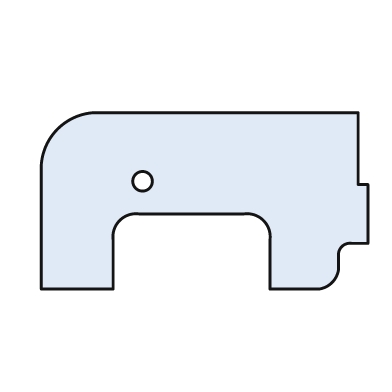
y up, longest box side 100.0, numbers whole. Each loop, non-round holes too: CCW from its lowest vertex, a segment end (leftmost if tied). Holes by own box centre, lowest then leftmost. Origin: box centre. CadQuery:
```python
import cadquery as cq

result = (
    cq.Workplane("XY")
    .moveTo(-50.0, -27.0)
    .lineTo(-28.0, -27.0)
    .lineTo(-28.0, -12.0)
    .threePointArc((-26.0, -6.0), (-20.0, -4.0))
    .lineTo(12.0, -4.0)
    .threePointArc((18.0, -6.0), (20.0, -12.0))
    .lineTo(20.0, -27.0)
    .lineTo(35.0, -27.0)
    .threePointArc((39.0, -25.0), (41.0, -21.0))
    .lineTo(41.0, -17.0)
    .threePointArc((42.0, -14.0), (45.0, -13.0))
    .lineTo(50.0, -13.0)
    .lineTo(50.0, 5.0)
    .lineTo(47.0, 5.0)
    .lineTo(47.0, 27.0)
    .lineTo(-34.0, 27.0)
    .threePointArc((-45.0, 22.0), (-50.0, 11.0))
    .close()
    .moveTo(-19.0, 6.0)
    .circle(3.0)
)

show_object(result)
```